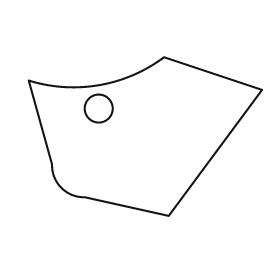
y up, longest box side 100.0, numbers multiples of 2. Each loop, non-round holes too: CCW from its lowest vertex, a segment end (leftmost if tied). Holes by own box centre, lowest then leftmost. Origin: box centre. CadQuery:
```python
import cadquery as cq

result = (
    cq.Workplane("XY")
    .moveTo(10.0, -34.0)
    .lineTo(50.0, 20.0)
    .lineTo(8.0, 34.0)
    .threePointArc((-20.0, 22.0), (-50.0, 24.0))
    .lineTo(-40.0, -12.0)
    .threePointArc((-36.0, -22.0), (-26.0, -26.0))
    .close()
    .moveTo(-20.0, 12.0)
    .circle(6.0)
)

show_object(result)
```